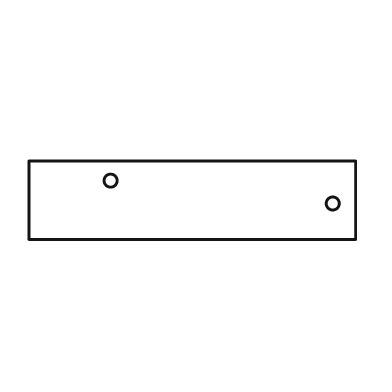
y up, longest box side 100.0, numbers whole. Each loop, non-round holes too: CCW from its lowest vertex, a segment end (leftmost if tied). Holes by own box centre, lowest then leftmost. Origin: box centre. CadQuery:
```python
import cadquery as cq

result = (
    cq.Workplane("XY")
    .moveTo(-50.0, -12.0)
    .lineTo(50.0, -12.0)
    .lineTo(50.0, 12.0)
    .lineTo(-50.0, 12.0)
    .close()
    .moveTo(43.0, -1.0)
    .circle(2.0)
    .moveTo(-25.0, 6.0)
    .circle(2.0)
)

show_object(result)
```